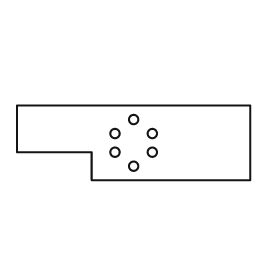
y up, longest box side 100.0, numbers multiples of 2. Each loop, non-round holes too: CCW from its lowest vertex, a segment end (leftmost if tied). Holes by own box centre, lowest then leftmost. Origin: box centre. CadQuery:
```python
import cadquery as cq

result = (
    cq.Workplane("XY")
    .moveTo(-18.0, -16.0)
    .lineTo(50.0, -16.0)
    .lineTo(50.0, 16.0)
    .lineTo(-50.0, 16.0)
    .lineTo(-50.0, -4.0)
    .lineTo(-18.0, -4.0)
    .close()
    .moveTo(0.0, -10.0)
    .circle(2.0)
    .moveTo(-8.0, -4.0)
    .circle(2.0)
    .moveTo(8.0, -4.0)
    .circle(2.0)
    .moveTo(-8.0, 4.0)
    .circle(2.0)
    .moveTo(8.0, 4.0)
    .circle(2.0)
    .moveTo(0.0, 10.0)
    .circle(2.0)
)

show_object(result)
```